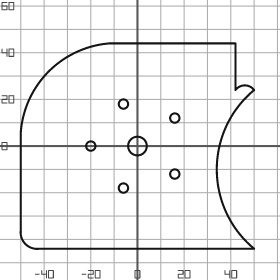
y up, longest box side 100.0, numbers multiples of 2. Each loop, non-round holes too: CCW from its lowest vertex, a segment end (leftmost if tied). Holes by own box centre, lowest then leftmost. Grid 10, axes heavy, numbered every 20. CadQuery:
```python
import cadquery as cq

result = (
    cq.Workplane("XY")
    .moveTo(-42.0, -44.0)
    .lineTo(50.0, -44.0)
    .threePointArc((34.0, -10.0), (50.0, 24.0))
    .threePointArc((46.0, 26.0), (42.0, 24.0))
    .lineTo(42.0, 44.0)
    .lineTo(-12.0, 44.0)
    .threePointArc((-38.0, 32.0), (-50.0, 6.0))
    .lineTo(-50.0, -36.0)
    .threePointArc((-48.0, -42.0), (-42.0, -44.0))
    .close()
    .moveTo(-6.0, -18.0)
    .circle(2.0)
    .moveTo(16.0, -12.0)
    .circle(2.0)
    .moveTo(-20.0, 0.0)
    .circle(2.0)
    .moveTo(0.0, 0.0)
    .circle(4.0)
    .moveTo(16.0, 12.0)
    .circle(2.0)
    .moveTo(-6.0, 18.0)
    .circle(2.0)
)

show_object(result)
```